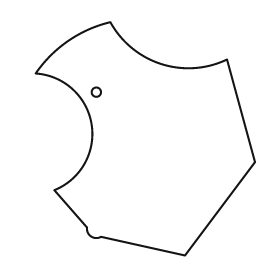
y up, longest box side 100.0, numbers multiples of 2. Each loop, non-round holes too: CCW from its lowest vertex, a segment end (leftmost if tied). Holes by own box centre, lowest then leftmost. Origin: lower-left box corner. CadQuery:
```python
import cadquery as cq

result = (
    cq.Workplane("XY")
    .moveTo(64.0, 0.0)
    .lineTo(94.0, 40.0)
    .lineTo(82.0, 84.0)
    .threePointArc((54.0, 82.0), (32.0, 100.0))
    .threePointArc((14.0, 92.0), (0.0, 78.0))
    .threePointArc((24.0, 56.0), (8.0, 28.0))
    .lineTo(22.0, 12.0)
    .threePointArc((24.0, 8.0), (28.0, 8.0))
    .close()
    .moveTo(26.0, 70.0)
    .circle(2.0)
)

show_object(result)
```